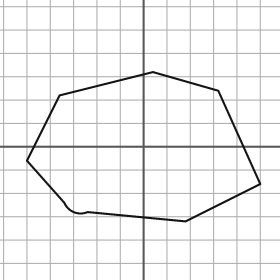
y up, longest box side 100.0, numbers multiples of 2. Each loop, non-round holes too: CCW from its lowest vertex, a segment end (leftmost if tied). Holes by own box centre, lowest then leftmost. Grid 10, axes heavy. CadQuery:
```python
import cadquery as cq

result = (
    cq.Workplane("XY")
    .moveTo(18.0, -32.0)
    .lineTo(50.0, -16.0)
    .lineTo(32.0, 24.0)
    .lineTo(4.0, 32.0)
    .lineTo(-36.0, 22.0)
    .lineTo(-50.0, -6.0)
    .lineTo(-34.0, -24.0)
    .threePointArc((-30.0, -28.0), (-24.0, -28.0))
    .close()
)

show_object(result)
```